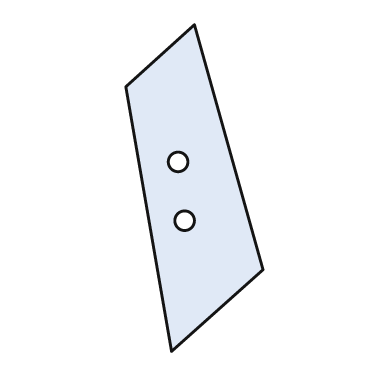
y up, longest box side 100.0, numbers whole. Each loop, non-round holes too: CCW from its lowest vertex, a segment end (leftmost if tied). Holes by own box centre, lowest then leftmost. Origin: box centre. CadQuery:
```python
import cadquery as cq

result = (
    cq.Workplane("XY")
    .moveTo(-7.0, -50.0)
    .lineTo(21.0, -25.0)
    .lineTo(0.0, 50.0)
    .lineTo(-21.0, 31.0)
    .close()
    .moveTo(-3.0, -10.0)
    .circle(3.0)
    .moveTo(-5.0, 8.0)
    .circle(3.0)
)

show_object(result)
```